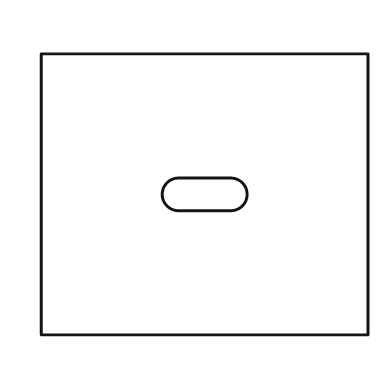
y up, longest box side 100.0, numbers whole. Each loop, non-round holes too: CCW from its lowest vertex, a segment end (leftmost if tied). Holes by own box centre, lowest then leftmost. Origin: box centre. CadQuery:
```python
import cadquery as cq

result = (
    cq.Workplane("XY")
    .moveTo(-50.0, -43.0)
    .lineTo(50.0, -43.0)
    .lineTo(50.0, 43.0)
    .lineTo(-50.0, 43.0)
    .close()
    .moveTo(-8.0, -5.0)
    .lineTo(8.0, -5.0)
    .threePointArc((13.0, 0.0), (8.0, 5.0))
    .lineTo(-8.0, 5.0)
    .threePointArc((-13.0, 0.0), (-8.0, -5.0))
    .close()
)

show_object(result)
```